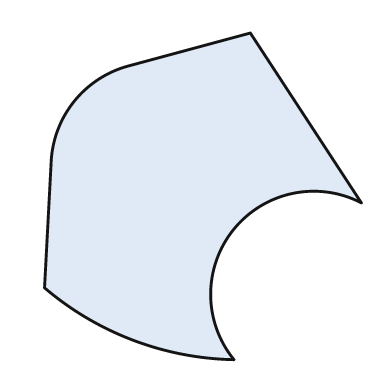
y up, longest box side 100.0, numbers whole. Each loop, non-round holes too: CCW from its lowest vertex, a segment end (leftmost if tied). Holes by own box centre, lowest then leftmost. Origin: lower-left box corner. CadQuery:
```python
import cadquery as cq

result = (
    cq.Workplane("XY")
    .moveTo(58.0, 0.0)
    .threePointArc((58.0, 40.0), (97.0, 48.0))
    .lineTo(63.0, 100.0)
    .lineTo(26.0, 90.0)
    .threePointArc((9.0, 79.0), (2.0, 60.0))
    .lineTo(0.0, 22.0)
    .threePointArc((27.0, 6.0), (58.0, 0.0))
    .close()
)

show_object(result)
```